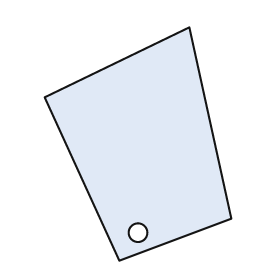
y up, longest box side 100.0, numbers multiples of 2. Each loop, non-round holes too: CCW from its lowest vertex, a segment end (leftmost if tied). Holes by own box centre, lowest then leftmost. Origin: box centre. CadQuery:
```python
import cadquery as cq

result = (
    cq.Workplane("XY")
    .moveTo(-8.0, -50.0)
    .lineTo(40.0, -32.0)
    .lineTo(22.0, 50.0)
    .lineTo(-40.0, 20.0)
    .close()
    .moveTo(0.0, -38.0)
    .circle(4.0)
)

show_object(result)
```